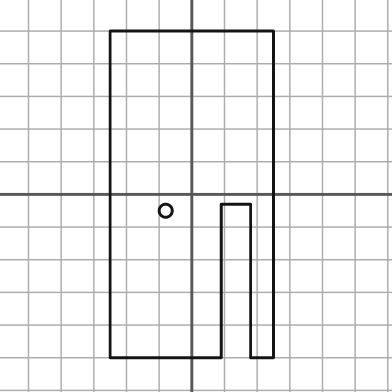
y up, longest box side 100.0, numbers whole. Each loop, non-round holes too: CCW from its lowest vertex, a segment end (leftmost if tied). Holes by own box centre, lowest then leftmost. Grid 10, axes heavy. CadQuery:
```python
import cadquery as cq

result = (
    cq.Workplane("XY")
    .moveTo(-25.0, -50.0)
    .lineTo(9.0, -50.0)
    .lineTo(9.0, -3.0)
    .lineTo(18.0, -3.0)
    .lineTo(18.0, -50.0)
    .lineTo(25.0, -50.0)
    .lineTo(25.0, 50.0)
    .lineTo(-25.0, 50.0)
    .close()
    .moveTo(-8.0, -5.0)
    .circle(2.0)
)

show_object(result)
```